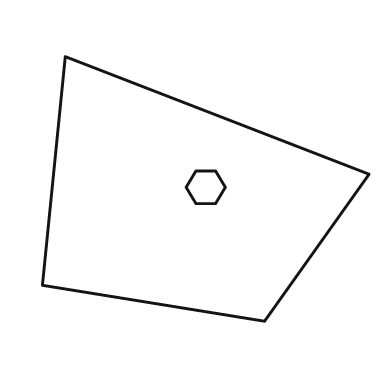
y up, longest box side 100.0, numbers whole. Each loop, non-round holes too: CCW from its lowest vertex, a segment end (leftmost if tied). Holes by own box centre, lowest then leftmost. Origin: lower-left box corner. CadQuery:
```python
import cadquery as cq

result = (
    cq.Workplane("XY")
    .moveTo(68.0, 0.0)
    .lineTo(100.0, 45.0)
    .lineTo(7.0, 81.0)
    .lineTo(0.0, 11.0)
    .close()
    .moveTo(47.0, 36.0)
    .lineTo(53.0, 36.0)
    .lineTo(56.0, 41.0)
    .lineTo(53.0, 46.0)
    .lineTo(47.0, 46.0)
    .lineTo(44.0, 41.0)
    .close()
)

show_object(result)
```